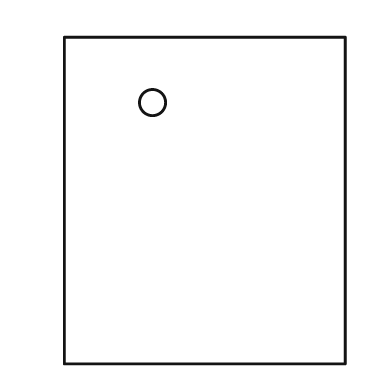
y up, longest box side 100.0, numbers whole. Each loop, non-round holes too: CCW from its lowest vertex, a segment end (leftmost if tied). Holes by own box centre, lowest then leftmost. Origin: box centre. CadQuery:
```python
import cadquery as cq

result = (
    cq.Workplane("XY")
    .moveTo(-43.0, -50.0)
    .lineTo(43.0, -50.0)
    .lineTo(43.0, 50.0)
    .lineTo(-43.0, 50.0)
    .close()
    .moveTo(-16.0, 30.0)
    .circle(4.0)
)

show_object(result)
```